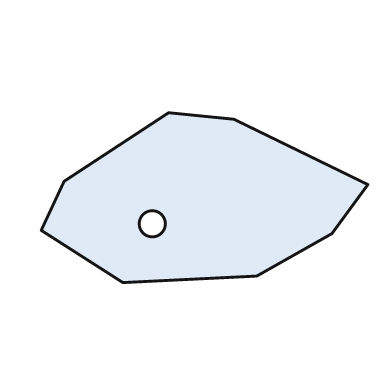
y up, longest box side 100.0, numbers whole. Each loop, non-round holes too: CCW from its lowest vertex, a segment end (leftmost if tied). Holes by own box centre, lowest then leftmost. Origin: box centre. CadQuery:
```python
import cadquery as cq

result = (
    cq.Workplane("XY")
    .moveTo(-25.0, -26.0)
    .lineTo(16.0, -24.0)
    .lineTo(39.0, -11.0)
    .lineTo(50.0, 4.0)
    .lineTo(9.0, 24.0)
    .lineTo(-11.0, 26.0)
    .lineTo(-43.0, 5.0)
    .lineTo(-50.0, -10.0)
    .close()
    .moveTo(-16.0, -8.0)
    .circle(4.0)
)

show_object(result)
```